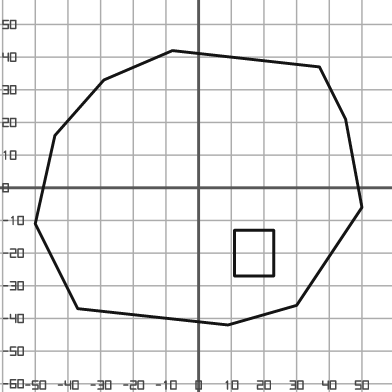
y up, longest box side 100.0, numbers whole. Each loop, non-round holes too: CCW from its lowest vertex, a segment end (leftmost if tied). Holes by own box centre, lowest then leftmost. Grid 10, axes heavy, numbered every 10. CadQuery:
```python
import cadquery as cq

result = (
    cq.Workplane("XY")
    .moveTo(9.0, -42.0)
    .lineTo(30.0, -36.0)
    .lineTo(50.0, -6.0)
    .lineTo(45.0, 21.0)
    .lineTo(37.0, 37.0)
    .lineTo(-8.0, 42.0)
    .lineTo(-29.0, 33.0)
    .lineTo(-44.0, 16.0)
    .lineTo(-50.0, -11.0)
    .lineTo(-37.0, -37.0)
    .close()
    .moveTo(11.0, -27.0)
    .lineTo(23.0, -27.0)
    .lineTo(23.0, -13.0)
    .lineTo(11.0, -13.0)
    .close()
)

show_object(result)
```